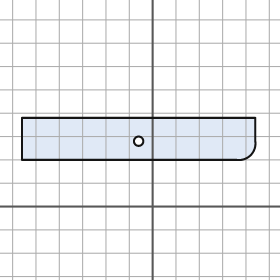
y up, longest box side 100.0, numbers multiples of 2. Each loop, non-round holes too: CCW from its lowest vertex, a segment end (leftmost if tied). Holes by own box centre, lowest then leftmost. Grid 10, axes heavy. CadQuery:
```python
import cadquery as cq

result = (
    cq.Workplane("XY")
    .moveTo(-56.0, 20.0)
    .lineTo(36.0, 20.0)
    .threePointArc((42.0, 22.0), (44.0, 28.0))
    .lineTo(44.0, 38.0)
    .lineTo(-56.0, 38.0)
    .close()
    .moveTo(-6.0, 28.0)
    .circle(2.0)
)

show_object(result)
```